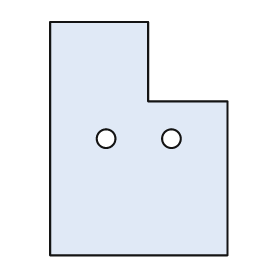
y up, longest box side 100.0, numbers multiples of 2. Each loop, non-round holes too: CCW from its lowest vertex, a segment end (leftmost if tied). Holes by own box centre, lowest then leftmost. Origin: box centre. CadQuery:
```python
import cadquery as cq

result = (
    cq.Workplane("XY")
    .moveTo(-38.0, -50.0)
    .lineTo(38.0, -50.0)
    .lineTo(38.0, 16.0)
    .lineTo(4.0, 16.0)
    .lineTo(4.0, 50.0)
    .lineTo(-38.0, 50.0)
    .close()
    .moveTo(-14.0, 0.0)
    .circle(4.0)
    .moveTo(14.0, 0.0)
    .circle(4.0)
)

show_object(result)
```